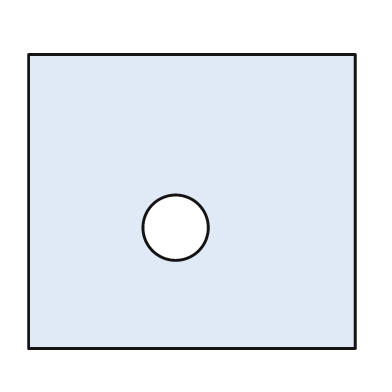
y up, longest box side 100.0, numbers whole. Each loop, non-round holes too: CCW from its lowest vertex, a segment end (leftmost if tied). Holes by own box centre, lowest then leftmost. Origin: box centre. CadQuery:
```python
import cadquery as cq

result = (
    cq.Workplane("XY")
    .moveTo(-50.0, -45.0)
    .lineTo(50.0, -45.0)
    .lineTo(50.0, 45.0)
    .lineTo(-50.0, 45.0)
    .close()
    .moveTo(-5.0, -8.0)
    .circle(10.0)
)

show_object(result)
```